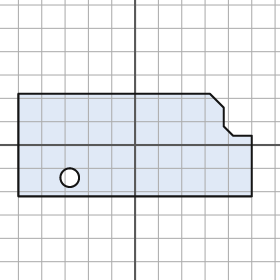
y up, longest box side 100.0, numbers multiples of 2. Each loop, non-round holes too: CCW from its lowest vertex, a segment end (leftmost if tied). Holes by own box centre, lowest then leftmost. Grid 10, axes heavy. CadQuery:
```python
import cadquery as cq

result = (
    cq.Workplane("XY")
    .moveTo(-50.0, -22.0)
    .lineTo(50.0, -22.0)
    .lineTo(50.0, 4.0)
    .lineTo(42.0, 4.0)
    .lineTo(38.0, 8.0)
    .lineTo(38.0, 16.0)
    .lineTo(32.0, 22.0)
    .lineTo(-50.0, 22.0)
    .close()
    .moveTo(-28.0, -14.0)
    .circle(4.0)
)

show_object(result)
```